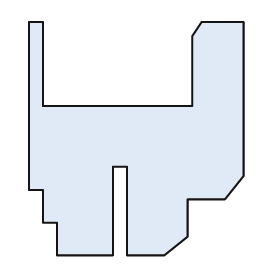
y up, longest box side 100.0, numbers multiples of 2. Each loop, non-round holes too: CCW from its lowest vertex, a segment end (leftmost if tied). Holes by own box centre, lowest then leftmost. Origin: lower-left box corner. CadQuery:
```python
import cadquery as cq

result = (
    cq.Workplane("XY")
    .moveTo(12.0, 0.0)
    .lineTo(36.0, 0.0)
    .lineTo(36.0, 38.0)
    .lineTo(42.0, 38.0)
    .lineTo(42.0, 0.0)
    .lineTo(58.0, 0.0)
    .lineTo(68.0, 8.0)
    .lineTo(68.0, 24.0)
    .lineTo(84.0, 24.0)
    .lineTo(92.0, 34.0)
    .lineTo(92.0, 100.0)
    .lineTo(74.0, 100.0)
    .lineTo(70.0, 94.0)
    .lineTo(70.0, 64.0)
    .lineTo(6.0, 64.0)
    .lineTo(6.0, 100.0)
    .lineTo(0.0, 100.0)
    .lineTo(0.0, 28.0)
    .lineTo(6.0, 28.0)
    .lineTo(6.0, 14.0)
    .lineTo(12.0, 14.0)
    .close()
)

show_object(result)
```